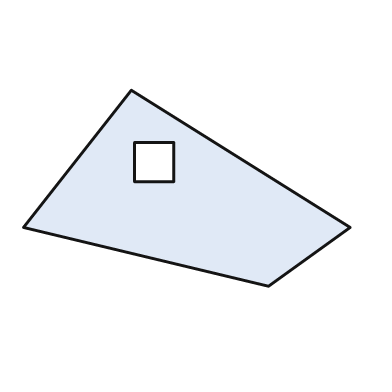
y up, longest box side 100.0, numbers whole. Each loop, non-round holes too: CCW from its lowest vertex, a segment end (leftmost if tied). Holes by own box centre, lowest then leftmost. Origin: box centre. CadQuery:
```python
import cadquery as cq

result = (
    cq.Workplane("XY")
    .moveTo(25.0, -30.0)
    .lineTo(50.0, -12.0)
    .lineTo(-17.0, 30.0)
    .lineTo(-50.0, -12.0)
    .close()
    .moveTo(-16.0, 2.0)
    .lineTo(-4.0, 2.0)
    .lineTo(-4.0, 14.0)
    .lineTo(-16.0, 14.0)
    .close()
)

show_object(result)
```